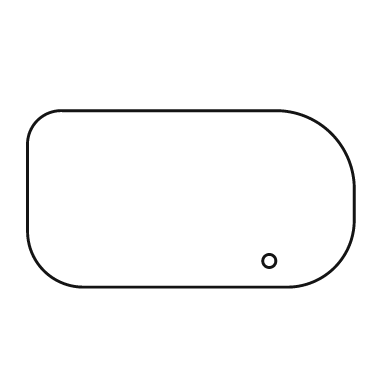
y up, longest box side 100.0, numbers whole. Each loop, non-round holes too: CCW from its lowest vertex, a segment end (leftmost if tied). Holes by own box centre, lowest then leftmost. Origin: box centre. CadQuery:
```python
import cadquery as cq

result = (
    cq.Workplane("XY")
    .moveTo(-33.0, -27.0)
    .lineTo(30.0, -27.0)
    .threePointArc((44.0, -21.0), (50.0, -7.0))
    .lineTo(50.0, 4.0)
    .threePointArc((43.0, 20.0), (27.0, 27.0))
    .lineTo(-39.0, 27.0)
    .threePointArc((-47.0, 24.0), (-50.0, 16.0))
    .lineTo(-50.0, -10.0)
    .threePointArc((-45.0, -22.0), (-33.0, -27.0))
    .close()
    .moveTo(24.0, -19.0)
    .circle(2.0)
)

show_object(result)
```